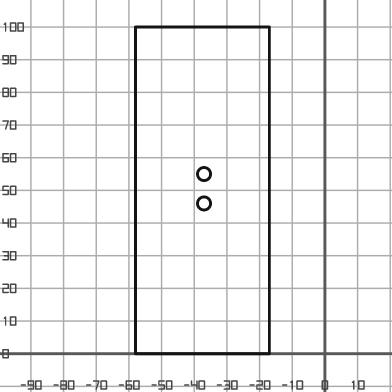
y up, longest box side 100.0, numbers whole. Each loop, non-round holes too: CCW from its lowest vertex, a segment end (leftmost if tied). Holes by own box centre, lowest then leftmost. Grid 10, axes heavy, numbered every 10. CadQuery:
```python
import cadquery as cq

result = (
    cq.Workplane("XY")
    .moveTo(-58.0, 0.0)
    .lineTo(-17.0, 0.0)
    .lineTo(-17.0, 100.0)
    .lineTo(-58.0, 100.0)
    .close()
    .moveTo(-37.0, 46.0)
    .circle(2.0)
    .moveTo(-37.0, 55.0)
    .circle(2.0)
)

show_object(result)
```